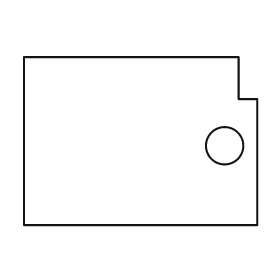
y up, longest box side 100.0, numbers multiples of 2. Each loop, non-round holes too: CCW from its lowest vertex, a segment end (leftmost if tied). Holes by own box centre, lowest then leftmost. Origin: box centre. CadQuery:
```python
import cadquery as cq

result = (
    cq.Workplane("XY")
    .moveTo(-50.0, -36.0)
    .lineTo(50.0, -36.0)
    .lineTo(50.0, 18.0)
    .lineTo(42.0, 18.0)
    .lineTo(42.0, 36.0)
    .lineTo(-50.0, 36.0)
    .close()
    .moveTo(36.0, -2.0)
    .circle(8.0)
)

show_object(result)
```